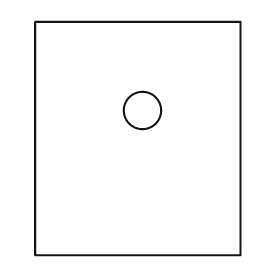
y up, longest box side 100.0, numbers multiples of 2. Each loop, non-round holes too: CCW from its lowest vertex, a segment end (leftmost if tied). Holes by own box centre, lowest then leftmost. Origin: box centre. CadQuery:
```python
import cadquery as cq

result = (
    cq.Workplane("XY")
    .moveTo(-44.0, -50.0)
    .lineTo(44.0, -50.0)
    .lineTo(44.0, 50.0)
    .lineTo(-44.0, 50.0)
    .close()
    .moveTo(2.0, 12.0)
    .circle(8.0)
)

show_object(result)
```